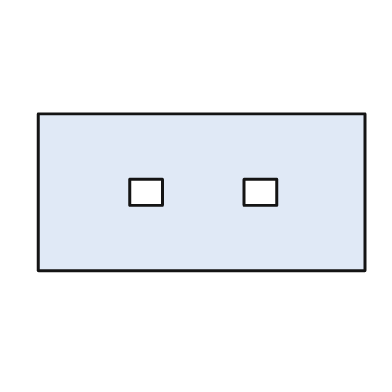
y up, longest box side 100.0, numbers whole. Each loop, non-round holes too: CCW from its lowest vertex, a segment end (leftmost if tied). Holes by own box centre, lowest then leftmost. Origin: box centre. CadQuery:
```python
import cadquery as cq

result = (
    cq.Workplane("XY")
    .moveTo(-50.0, -24.0)
    .lineTo(50.0, -24.0)
    .lineTo(50.0, 24.0)
    .lineTo(-50.0, 24.0)
    .close()
    .moveTo(-22.0, -4.0)
    .lineTo(-12.0, -4.0)
    .lineTo(-12.0, 4.0)
    .lineTo(-22.0, 4.0)
    .close()
    .moveTo(13.0, -4.0)
    .lineTo(23.0, -4.0)
    .lineTo(23.0, 4.0)
    .lineTo(13.0, 4.0)
    .close()
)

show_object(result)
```